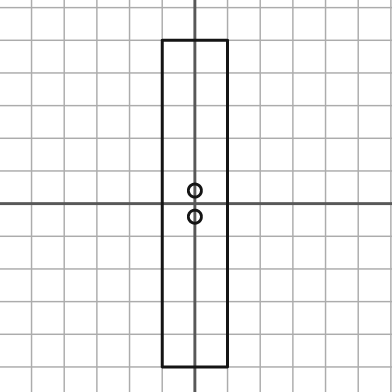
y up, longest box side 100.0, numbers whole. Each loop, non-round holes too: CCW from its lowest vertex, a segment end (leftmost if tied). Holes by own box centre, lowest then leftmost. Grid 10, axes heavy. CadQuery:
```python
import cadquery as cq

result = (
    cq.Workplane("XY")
    .moveTo(-10.0, -50.0)
    .lineTo(10.0, -50.0)
    .lineTo(10.0, 50.0)
    .lineTo(-10.0, 50.0)
    .close()
    .moveTo(0.0, -4.0)
    .circle(2.0)
    .moveTo(0.0, 4.0)
    .circle(2.0)
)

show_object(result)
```